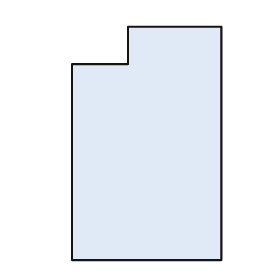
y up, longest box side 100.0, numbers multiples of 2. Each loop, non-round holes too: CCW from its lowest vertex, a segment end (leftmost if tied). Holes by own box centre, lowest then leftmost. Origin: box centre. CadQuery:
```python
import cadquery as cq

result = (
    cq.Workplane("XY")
    .moveTo(-32.0, -50.0)
    .lineTo(32.0, -50.0)
    .lineTo(32.0, 50.0)
    .lineTo(-8.0, 50.0)
    .lineTo(-8.0, 34.0)
    .lineTo(-32.0, 34.0)
    .close()
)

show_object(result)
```